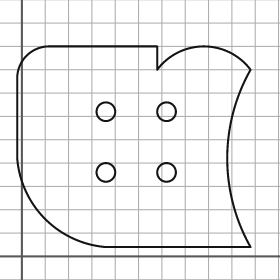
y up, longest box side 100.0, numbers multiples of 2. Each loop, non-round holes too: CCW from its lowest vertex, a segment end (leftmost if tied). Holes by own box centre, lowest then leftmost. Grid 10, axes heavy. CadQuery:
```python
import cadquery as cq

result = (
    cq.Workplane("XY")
    .moveTo(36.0, 4.0)
    .lineTo(98.0, 4.0)
    .threePointArc((88.0, 42.0), (98.0, 80.0))
    .threePointArc((78.0, 90.0), (58.0, 80.0))
    .lineTo(58.0, 90.0)
    .lineTo(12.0, 90.0)
    .threePointArc((2.0, 86.0), (-2.0, 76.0))
    .lineTo(-2.0, 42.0)
    .threePointArc((10.0, 16.0), (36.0, 4.0))
    .close()
    .moveTo(36.0, 36.0)
    .circle(4.0)
    .moveTo(62.0, 36.0)
    .circle(4.0)
    .moveTo(36.0, 62.0)
    .circle(4.0)
    .moveTo(62.0, 62.0)
    .circle(4.0)
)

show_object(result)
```